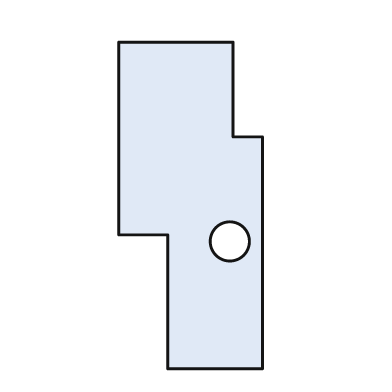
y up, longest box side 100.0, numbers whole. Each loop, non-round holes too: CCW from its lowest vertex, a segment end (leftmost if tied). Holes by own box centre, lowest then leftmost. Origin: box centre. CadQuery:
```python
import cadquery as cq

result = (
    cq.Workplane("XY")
    .moveTo(-7.0, -50.0)
    .lineTo(22.0, -50.0)
    .lineTo(22.0, 21.0)
    .lineTo(13.0, 21.0)
    .lineTo(13.0, 50.0)
    .lineTo(-22.0, 50.0)
    .lineTo(-22.0, -9.0)
    .lineTo(-7.0, -9.0)
    .close()
    .moveTo(12.0, -11.0)
    .circle(6.0)
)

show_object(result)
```